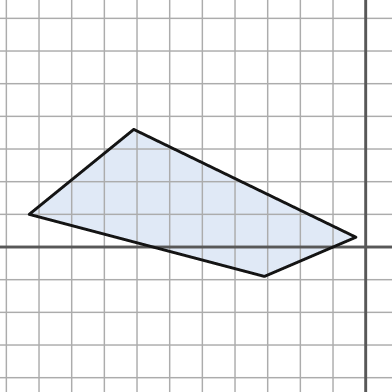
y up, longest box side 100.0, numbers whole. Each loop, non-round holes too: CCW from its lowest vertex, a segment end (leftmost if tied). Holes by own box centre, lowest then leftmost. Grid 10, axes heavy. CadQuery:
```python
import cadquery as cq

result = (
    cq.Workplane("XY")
    .moveTo(-31.0, -9.0)
    .lineTo(-3.0, 3.0)
    .lineTo(-71.0, 36.0)
    .lineTo(-103.0, 10.0)
    .close()
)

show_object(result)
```